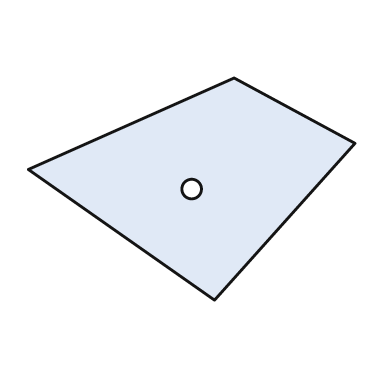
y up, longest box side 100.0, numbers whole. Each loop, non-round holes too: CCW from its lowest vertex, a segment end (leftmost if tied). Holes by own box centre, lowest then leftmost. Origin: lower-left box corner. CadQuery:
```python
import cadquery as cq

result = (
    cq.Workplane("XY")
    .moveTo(57.0, 0.0)
    .lineTo(100.0, 48.0)
    .lineTo(63.0, 68.0)
    .lineTo(0.0, 40.0)
    .close()
    .moveTo(50.0, 34.0)
    .circle(3.0)
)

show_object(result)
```